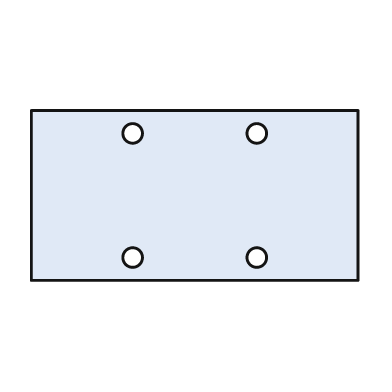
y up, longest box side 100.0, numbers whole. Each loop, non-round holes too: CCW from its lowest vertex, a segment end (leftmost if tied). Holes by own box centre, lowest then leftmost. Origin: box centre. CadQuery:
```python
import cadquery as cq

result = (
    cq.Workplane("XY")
    .moveTo(-50.0, -26.0)
    .lineTo(50.0, -26.0)
    .lineTo(50.0, 26.0)
    .lineTo(-50.0, 26.0)
    .close()
    .moveTo(-19.0, -19.0)
    .circle(3.0)
    .moveTo(19.0, -19.0)
    .circle(3.0)
    .moveTo(-19.0, 19.0)
    .circle(3.0)
    .moveTo(19.0, 19.0)
    .circle(3.0)
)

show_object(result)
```